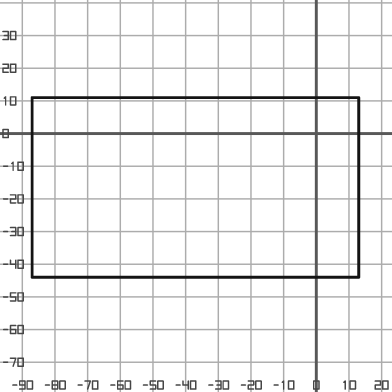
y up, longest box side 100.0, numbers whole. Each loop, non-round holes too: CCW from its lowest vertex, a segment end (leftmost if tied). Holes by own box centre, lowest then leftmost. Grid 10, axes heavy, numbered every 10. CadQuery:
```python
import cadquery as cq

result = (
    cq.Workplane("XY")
    .moveTo(-87.0, -44.0)
    .lineTo(13.0, -44.0)
    .lineTo(13.0, 11.0)
    .lineTo(-87.0, 11.0)
    .close()
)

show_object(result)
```